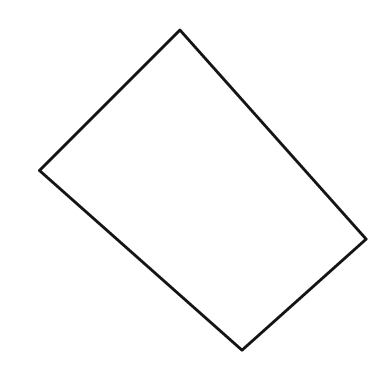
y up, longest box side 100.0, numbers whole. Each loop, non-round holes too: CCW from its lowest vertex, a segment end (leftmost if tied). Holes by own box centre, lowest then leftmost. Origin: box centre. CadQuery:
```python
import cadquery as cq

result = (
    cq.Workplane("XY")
    .moveTo(12.0, -49.0)
    .lineTo(50.0, -15.0)
    .lineTo(-7.0, 49.0)
    .lineTo(-50.0, 6.0)
    .close()
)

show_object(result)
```